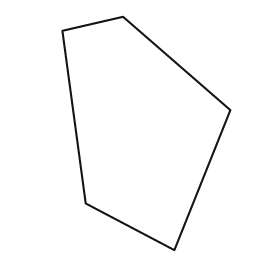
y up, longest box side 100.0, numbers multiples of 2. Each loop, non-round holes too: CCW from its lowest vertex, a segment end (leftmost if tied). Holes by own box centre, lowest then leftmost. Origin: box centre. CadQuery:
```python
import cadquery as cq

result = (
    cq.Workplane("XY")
    .moveTo(12.0, -50.0)
    .lineTo(36.0, 10.0)
    .lineTo(-10.0, 50.0)
    .lineTo(-36.0, 44.0)
    .lineTo(-26.0, -30.0)
    .close()
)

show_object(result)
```